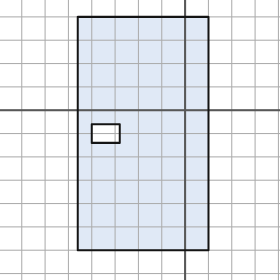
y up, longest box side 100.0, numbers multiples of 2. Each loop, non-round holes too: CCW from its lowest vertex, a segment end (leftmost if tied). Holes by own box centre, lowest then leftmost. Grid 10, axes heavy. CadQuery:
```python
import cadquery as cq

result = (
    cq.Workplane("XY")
    .moveTo(-46.0, -60.0)
    .lineTo(10.0, -60.0)
    .lineTo(10.0, 40.0)
    .lineTo(-46.0, 40.0)
    .close()
    .moveTo(-40.0, -14.0)
    .lineTo(-28.0, -14.0)
    .lineTo(-28.0, -6.0)
    .lineTo(-40.0, -6.0)
    .close()
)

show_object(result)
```